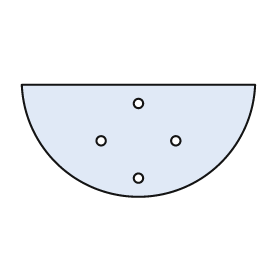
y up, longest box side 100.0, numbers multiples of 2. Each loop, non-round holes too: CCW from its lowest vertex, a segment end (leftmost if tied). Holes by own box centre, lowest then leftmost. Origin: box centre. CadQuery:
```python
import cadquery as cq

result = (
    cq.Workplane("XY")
    .moveTo(-50.0, 24.0)
    .threePointArc((0.0, -24.0), (50.0, 24.0))
    .close()
    .moveTo(0.0, -16.0)
    .circle(2.0)
    .moveTo(-16.0, 0.0)
    .circle(2.0)
    .moveTo(16.0, 0.0)
    .circle(2.0)
    .moveTo(0.0, 16.0)
    .circle(2.0)
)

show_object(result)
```